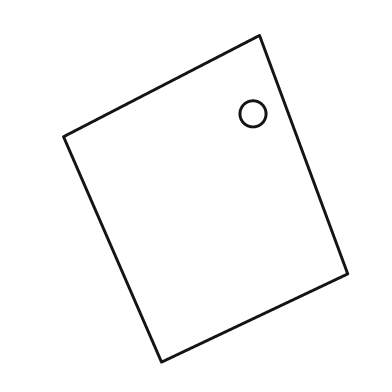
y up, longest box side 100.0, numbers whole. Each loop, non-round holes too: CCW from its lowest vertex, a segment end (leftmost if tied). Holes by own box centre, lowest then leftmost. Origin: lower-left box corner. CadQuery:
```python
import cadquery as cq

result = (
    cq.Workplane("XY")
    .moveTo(30.0, 0.0)
    .lineTo(87.0, 27.0)
    .lineTo(60.0, 100.0)
    .lineTo(0.0, 69.0)
    .close()
    .moveTo(58.0, 76.0)
    .circle(4.0)
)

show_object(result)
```